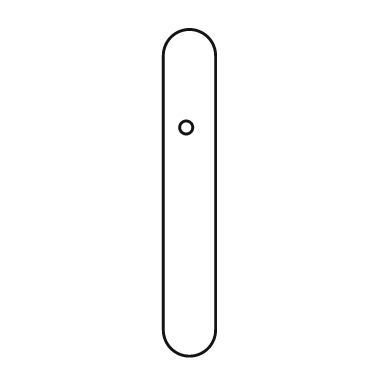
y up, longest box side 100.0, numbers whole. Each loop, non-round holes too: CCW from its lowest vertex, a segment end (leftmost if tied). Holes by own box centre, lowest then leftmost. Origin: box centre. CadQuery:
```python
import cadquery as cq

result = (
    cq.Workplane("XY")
    .moveTo(-8.0, -42.0)
    .threePointArc((0.0, -50.0), (8.0, -42.0))
    .lineTo(8.0, 42.0)
    .threePointArc((0.0, 50.0), (-8.0, 42.0))
    .close()
    .moveTo(-1.0, 20.0)
    .circle(2.0)
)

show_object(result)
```